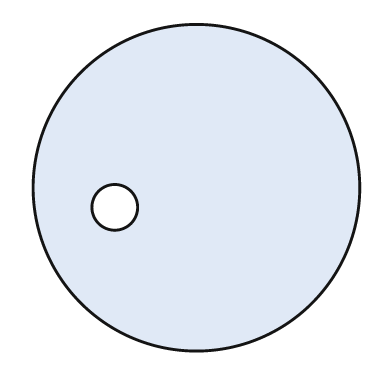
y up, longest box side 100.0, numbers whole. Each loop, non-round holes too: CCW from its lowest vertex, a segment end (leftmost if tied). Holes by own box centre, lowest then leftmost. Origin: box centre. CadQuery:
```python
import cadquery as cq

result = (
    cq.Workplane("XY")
    .moveTo(0.0, 0.0)
    .circle(50.0)
    .moveTo(-25.0, -6.0)
    .circle(7.0)
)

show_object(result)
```